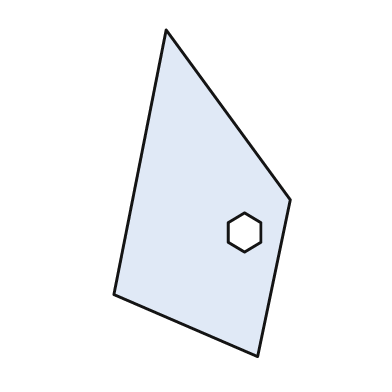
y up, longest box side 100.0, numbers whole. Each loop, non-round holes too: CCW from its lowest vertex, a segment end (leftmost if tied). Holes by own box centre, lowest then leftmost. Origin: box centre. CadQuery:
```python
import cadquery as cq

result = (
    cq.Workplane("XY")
    .moveTo(17.0, -50.0)
    .lineTo(27.0, -2.0)
    .lineTo(-11.0, 50.0)
    .lineTo(-27.0, -31.0)
    .close()
    .moveTo(13.0, -18.0)
    .lineTo(18.0, -15.0)
    .lineTo(18.0, -9.0)
    .lineTo(13.0, -6.0)
    .lineTo(8.0, -9.0)
    .lineTo(8.0, -15.0)
    .close()
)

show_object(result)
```